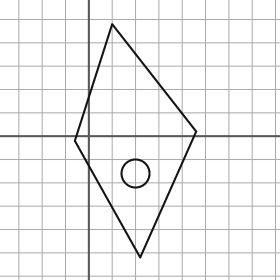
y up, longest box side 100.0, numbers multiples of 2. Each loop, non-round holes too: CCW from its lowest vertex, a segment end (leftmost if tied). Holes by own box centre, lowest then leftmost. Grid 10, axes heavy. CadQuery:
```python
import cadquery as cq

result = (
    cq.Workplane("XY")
    .moveTo(22.0, -52.0)
    .lineTo(46.0, 2.0)
    .lineTo(10.0, 48.0)
    .lineTo(-6.0, -2.0)
    .close()
    .moveTo(20.0, -16.0)
    .circle(6.0)
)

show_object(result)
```